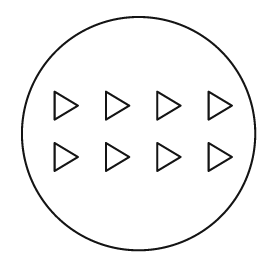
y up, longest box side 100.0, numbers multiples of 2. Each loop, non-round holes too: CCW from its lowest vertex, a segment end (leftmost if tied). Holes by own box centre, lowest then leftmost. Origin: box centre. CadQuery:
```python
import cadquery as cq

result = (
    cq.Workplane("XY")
    .moveTo(0.0, 0.0)
    .circle(50.0)
    .moveTo(-36.0, -16.0)
    .lineTo(-26.0, -10.0)
    .lineTo(-36.0, -4.0)
    .close()
    .moveTo(-14.0, -16.0)
    .lineTo(-4.0, -10.0)
    .lineTo(-14.0, -4.0)
    .close()
    .moveTo(8.0, -16.0)
    .lineTo(18.0, -10.0)
    .lineTo(8.0, -4.0)
    .close()
    .moveTo(30.0, -16.0)
    .lineTo(40.0, -10.0)
    .lineTo(30.0, -4.0)
    .close()
    .moveTo(-36.0, 6.0)
    .lineTo(-26.0, 12.0)
    .lineTo(-36.0, 18.0)
    .close()
    .moveTo(-14.0, 6.0)
    .lineTo(-4.0, 12.0)
    .lineTo(-14.0, 18.0)
    .close()
    .moveTo(8.0, 6.0)
    .lineTo(18.0, 12.0)
    .lineTo(8.0, 18.0)
    .close()
    .moveTo(30.0, 6.0)
    .lineTo(40.0, 12.0)
    .lineTo(30.0, 18.0)
    .close()
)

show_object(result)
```